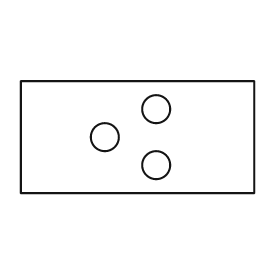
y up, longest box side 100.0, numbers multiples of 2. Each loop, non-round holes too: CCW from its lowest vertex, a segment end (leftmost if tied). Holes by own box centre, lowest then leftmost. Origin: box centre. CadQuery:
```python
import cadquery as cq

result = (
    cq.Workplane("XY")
    .moveTo(-50.0, -24.0)
    .lineTo(50.0, -24.0)
    .lineTo(50.0, 24.0)
    .lineTo(-50.0, 24.0)
    .close()
    .moveTo(8.0, -12.0)
    .circle(6.0)
    .moveTo(-14.0, 0.0)
    .circle(6.0)
    .moveTo(8.0, 12.0)
    .circle(6.0)
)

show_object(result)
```